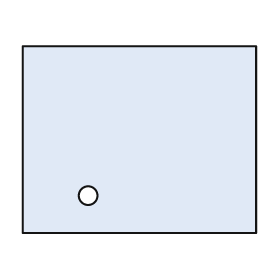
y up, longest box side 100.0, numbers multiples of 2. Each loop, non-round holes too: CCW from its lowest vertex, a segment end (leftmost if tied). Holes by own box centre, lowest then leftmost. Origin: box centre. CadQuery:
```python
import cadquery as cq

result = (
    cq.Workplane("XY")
    .moveTo(-50.0, -40.0)
    .lineTo(50.0, -40.0)
    .lineTo(50.0, 40.0)
    .lineTo(-50.0, 40.0)
    .close()
    .moveTo(-22.0, -24.0)
    .circle(4.0)
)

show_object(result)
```